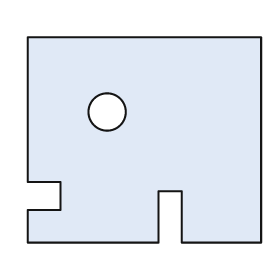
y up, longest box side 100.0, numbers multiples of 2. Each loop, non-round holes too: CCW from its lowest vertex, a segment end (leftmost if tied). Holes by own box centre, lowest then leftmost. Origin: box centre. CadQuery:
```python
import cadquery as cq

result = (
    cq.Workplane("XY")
    .moveTo(-50.0, -44.0)
    .lineTo(6.0, -44.0)
    .lineTo(6.0, -22.0)
    .lineTo(16.0, -22.0)
    .lineTo(16.0, -44.0)
    .lineTo(50.0, -44.0)
    .lineTo(50.0, 44.0)
    .lineTo(-50.0, 44.0)
    .lineTo(-50.0, -18.0)
    .lineTo(-36.0, -18.0)
    .lineTo(-36.0, -30.0)
    .lineTo(-50.0, -30.0)
    .close()
    .moveTo(-16.0, 12.0)
    .circle(8.0)
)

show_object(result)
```